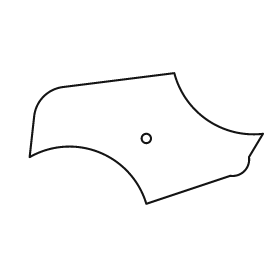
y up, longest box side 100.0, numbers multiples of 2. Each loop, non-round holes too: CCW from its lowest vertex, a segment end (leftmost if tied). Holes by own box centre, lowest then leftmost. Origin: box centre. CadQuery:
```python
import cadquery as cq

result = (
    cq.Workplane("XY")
    .moveTo(0.0, -28.0)
    .lineTo(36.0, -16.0)
    .threePointArc((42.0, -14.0), (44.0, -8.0))
    .lineTo(50.0, 2.0)
    .threePointArc((26.0, 8.0), (12.0, 28.0))
    .lineTo(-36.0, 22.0)
    .threePointArc((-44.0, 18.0), (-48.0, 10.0))
    .lineTo(-50.0, -8.0)
    .threePointArc((-20.0, -6.0), (0.0, -28.0))
    .close()
    .moveTo(0.0, 0.0)
    .circle(2.0)
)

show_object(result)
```